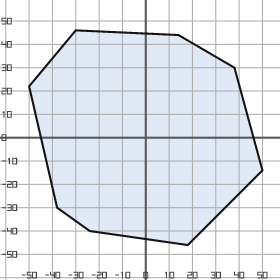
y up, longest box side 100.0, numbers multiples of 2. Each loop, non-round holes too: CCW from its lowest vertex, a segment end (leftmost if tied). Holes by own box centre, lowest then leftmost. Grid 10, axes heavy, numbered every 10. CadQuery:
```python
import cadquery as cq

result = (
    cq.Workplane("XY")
    .moveTo(18.0, -46.0)
    .lineTo(50.0, -14.0)
    .lineTo(38.0, 30.0)
    .lineTo(14.0, 44.0)
    .lineTo(-30.0, 46.0)
    .lineTo(-50.0, 22.0)
    .lineTo(-38.0, -30.0)
    .lineTo(-24.0, -40.0)
    .close()
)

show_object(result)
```